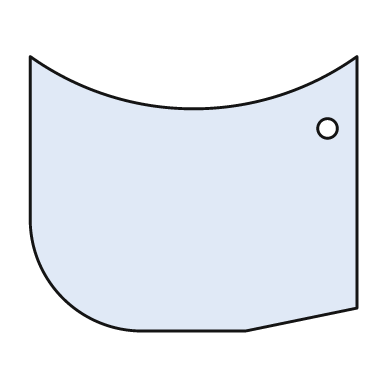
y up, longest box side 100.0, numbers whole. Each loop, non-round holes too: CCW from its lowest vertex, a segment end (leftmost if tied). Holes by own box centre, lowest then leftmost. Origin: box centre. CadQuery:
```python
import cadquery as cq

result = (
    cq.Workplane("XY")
    .moveTo(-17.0, -42.0)
    .lineTo(16.0, -42.0)
    .lineTo(50.0, -35.0)
    .lineTo(50.0, 42.0)
    .threePointArc((0.0, 26.0), (-50.0, 42.0))
    .lineTo(-50.0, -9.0)
    .threePointArc((-40.0, -32.0), (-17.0, -42.0))
    .close()
    .moveTo(41.0, 20.0)
    .circle(3.0)
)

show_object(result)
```